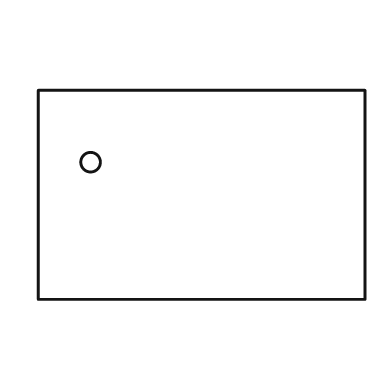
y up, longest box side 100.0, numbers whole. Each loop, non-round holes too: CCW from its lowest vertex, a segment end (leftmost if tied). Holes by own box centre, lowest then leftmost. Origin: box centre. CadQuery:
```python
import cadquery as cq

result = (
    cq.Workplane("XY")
    .moveTo(-50.0, -32.0)
    .lineTo(50.0, -32.0)
    .lineTo(50.0, 32.0)
    .lineTo(-50.0, 32.0)
    .close()
    .moveTo(-34.0, 10.0)
    .circle(3.0)
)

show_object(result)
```